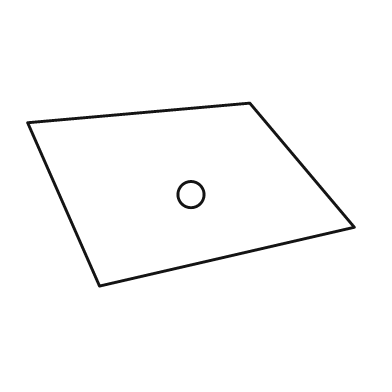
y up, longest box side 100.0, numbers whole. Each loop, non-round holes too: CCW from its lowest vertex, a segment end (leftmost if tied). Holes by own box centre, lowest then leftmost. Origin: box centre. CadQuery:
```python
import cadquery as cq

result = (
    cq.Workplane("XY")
    .moveTo(-28.0, -28.0)
    .lineTo(50.0, -10.0)
    .lineTo(18.0, 28.0)
    .lineTo(-50.0, 22.0)
    .close()
    .moveTo(0.0, 0.0)
    .circle(4.0)
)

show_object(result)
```